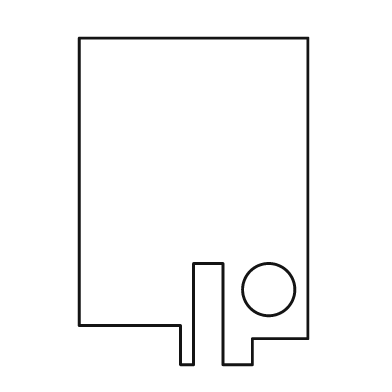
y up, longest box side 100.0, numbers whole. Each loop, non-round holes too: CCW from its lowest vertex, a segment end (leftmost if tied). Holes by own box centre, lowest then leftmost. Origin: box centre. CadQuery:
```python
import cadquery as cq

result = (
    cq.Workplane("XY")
    .moveTo(-4.0, -50.0)
    .lineTo(0.0, -50.0)
    .lineTo(0.0, -19.0)
    .lineTo(9.0, -19.0)
    .lineTo(9.0, -50.0)
    .lineTo(18.0, -50.0)
    .lineTo(18.0, -42.0)
    .lineTo(35.0, -42.0)
    .lineTo(35.0, 50.0)
    .lineTo(-35.0, 50.0)
    .lineTo(-35.0, -38.0)
    .lineTo(-4.0, -38.0)
    .close()
    .moveTo(23.0, -27.0)
    .circle(8.0)
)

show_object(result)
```